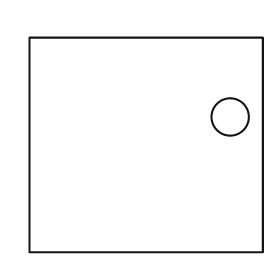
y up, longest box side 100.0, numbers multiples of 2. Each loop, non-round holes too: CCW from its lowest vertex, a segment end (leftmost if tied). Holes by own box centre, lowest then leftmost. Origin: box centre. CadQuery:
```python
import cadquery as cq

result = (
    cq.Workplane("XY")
    .moveTo(-50.0, -46.0)
    .lineTo(50.0, -46.0)
    .lineTo(50.0, 46.0)
    .lineTo(-50.0, 46.0)
    .close()
    .moveTo(36.0, 12.0)
    .circle(8.0)
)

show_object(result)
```